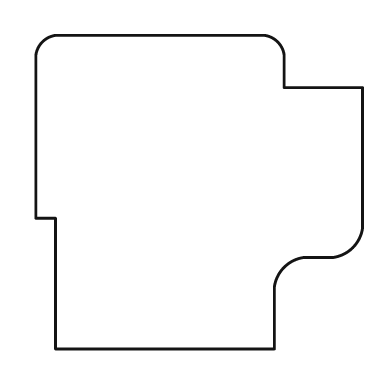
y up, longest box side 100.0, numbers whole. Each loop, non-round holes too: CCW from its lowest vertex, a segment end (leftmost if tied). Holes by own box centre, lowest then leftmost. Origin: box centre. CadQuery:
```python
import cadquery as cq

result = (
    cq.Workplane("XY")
    .moveTo(-44.0, -48.0)
    .lineTo(23.0, -48.0)
    .lineTo(23.0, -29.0)
    .threePointArc((26.0, -23.0), (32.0, -20.0))
    .lineTo(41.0, -20.0)
    .threePointArc((47.0, -17.0), (50.0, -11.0))
    .lineTo(50.0, 32.0)
    .lineTo(26.0, 32.0)
    .lineTo(26.0, 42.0)
    .threePointArc((24.0, 46.0), (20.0, 48.0))
    .lineTo(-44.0, 48.0)
    .threePointArc((-48.0, 46.0), (-50.0, 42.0))
    .lineTo(-50.0, -8.0)
    .lineTo(-44.0, -8.0)
    .close()
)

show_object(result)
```